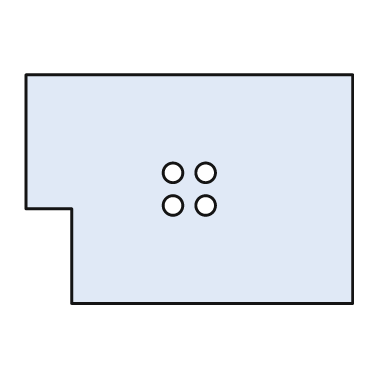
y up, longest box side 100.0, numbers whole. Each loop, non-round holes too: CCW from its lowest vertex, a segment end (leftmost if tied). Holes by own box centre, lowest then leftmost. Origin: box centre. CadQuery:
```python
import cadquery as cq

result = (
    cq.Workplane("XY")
    .moveTo(-36.0, -35.0)
    .lineTo(50.0, -35.0)
    .lineTo(50.0, 35.0)
    .lineTo(-50.0, 35.0)
    .lineTo(-50.0, -6.0)
    .lineTo(-36.0, -6.0)
    .close()
    .moveTo(-5.0, -5.0)
    .circle(3.0)
    .moveTo(5.0, -5.0)
    .circle(3.0)
    .moveTo(-5.0, 5.0)
    .circle(3.0)
    .moveTo(5.0, 5.0)
    .circle(3.0)
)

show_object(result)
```